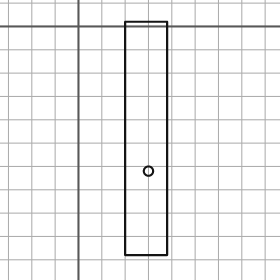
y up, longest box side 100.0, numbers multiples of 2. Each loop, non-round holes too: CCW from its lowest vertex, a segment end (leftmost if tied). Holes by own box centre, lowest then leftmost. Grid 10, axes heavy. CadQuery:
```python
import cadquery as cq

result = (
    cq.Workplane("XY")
    .moveTo(20.0, -98.0)
    .lineTo(38.0, -98.0)
    .lineTo(38.0, 2.0)
    .lineTo(20.0, 2.0)
    .close()
    .moveTo(30.0, -62.0)
    .circle(2.0)
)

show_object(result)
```